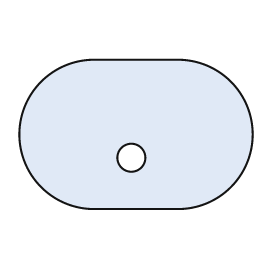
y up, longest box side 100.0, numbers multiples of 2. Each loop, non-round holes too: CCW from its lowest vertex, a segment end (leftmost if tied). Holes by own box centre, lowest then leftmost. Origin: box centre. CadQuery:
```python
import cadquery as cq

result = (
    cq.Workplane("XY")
    .moveTo(-18.0, -32.0)
    .lineTo(18.0, -32.0)
    .threePointArc((50.0, 0.0), (18.0, 32.0))
    .lineTo(-18.0, 32.0)
    .threePointArc((-50.0, 0.0), (-18.0, -32.0))
    .close()
    .moveTo(-2.0, -10.0)
    .circle(6.0)
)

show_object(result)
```